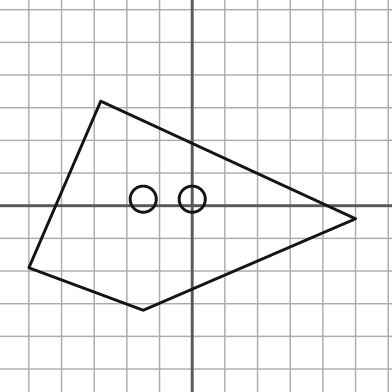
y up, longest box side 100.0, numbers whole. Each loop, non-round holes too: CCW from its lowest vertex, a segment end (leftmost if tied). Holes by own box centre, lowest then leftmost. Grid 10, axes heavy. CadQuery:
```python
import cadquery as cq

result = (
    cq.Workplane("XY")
    .moveTo(-15.0, -32.0)
    .lineTo(50.0, -4.0)
    .lineTo(-28.0, 32.0)
    .lineTo(-50.0, -19.0)
    .close()
    .moveTo(-15.0, 2.0)
    .circle(4.0)
    .moveTo(0.0, 2.0)
    .circle(4.0)
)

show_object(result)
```